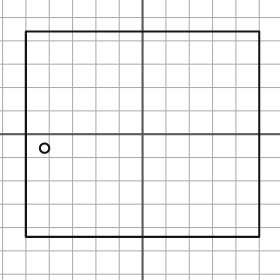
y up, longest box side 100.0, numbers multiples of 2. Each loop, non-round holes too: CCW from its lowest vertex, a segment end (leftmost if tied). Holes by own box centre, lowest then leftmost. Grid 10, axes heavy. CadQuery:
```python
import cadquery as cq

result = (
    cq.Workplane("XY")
    .moveTo(-50.0, -44.0)
    .lineTo(50.0, -44.0)
    .lineTo(50.0, 44.0)
    .lineTo(-50.0, 44.0)
    .close()
    .moveTo(-42.0, -6.0)
    .circle(2.0)
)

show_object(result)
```